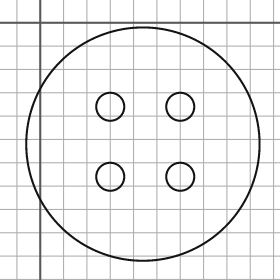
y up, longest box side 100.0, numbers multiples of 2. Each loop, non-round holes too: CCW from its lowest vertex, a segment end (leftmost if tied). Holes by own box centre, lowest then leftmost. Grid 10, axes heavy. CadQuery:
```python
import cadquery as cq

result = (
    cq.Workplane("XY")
    .moveTo(44.0, -52.0)
    .circle(50.0)
    .moveTo(30.0, -66.0)
    .circle(6.0)
    .moveTo(60.0, -66.0)
    .circle(6.0)
    .moveTo(30.0, -36.0)
    .circle(6.0)
    .moveTo(60.0, -36.0)
    .circle(6.0)
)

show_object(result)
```